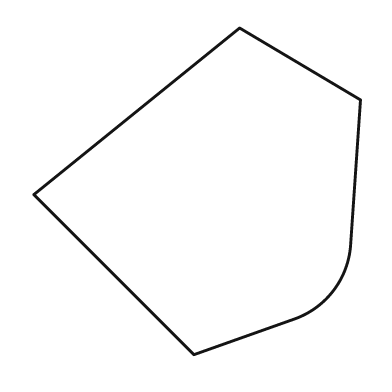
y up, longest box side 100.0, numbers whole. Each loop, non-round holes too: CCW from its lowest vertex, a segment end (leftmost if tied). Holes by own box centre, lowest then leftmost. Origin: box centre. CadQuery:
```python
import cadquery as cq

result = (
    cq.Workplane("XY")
    .moveTo(-1.0, -50.0)
    .lineTo(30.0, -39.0)
    .threePointArc((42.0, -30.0), (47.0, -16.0))
    .lineTo(50.0, 28.0)
    .lineTo(13.0, 50.0)
    .lineTo(-50.0, -1.0)
    .close()
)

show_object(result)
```